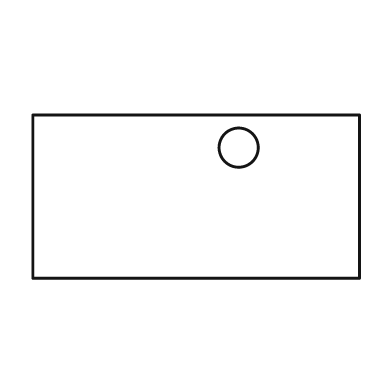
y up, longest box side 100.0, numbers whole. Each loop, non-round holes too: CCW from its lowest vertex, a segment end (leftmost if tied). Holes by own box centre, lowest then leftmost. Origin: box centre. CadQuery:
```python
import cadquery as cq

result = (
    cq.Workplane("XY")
    .moveTo(-50.0, -25.0)
    .lineTo(50.0, -25.0)
    .lineTo(50.0, 25.0)
    .lineTo(-50.0, 25.0)
    .close()
    .moveTo(13.0, 15.0)
    .circle(6.0)
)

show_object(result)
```